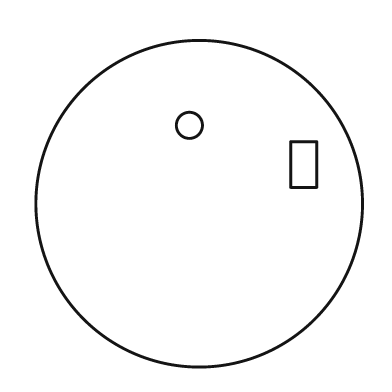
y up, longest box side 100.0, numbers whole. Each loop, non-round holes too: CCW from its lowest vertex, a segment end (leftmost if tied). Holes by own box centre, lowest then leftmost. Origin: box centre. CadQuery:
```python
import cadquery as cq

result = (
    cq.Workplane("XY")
    .moveTo(0.0, 0.0)
    .circle(50.0)
    .moveTo(28.0, 5.0)
    .lineTo(36.0, 5.0)
    .lineTo(36.0, 19.0)
    .lineTo(28.0, 19.0)
    .close()
    .moveTo(-3.0, 24.0)
    .circle(4.0)
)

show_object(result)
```